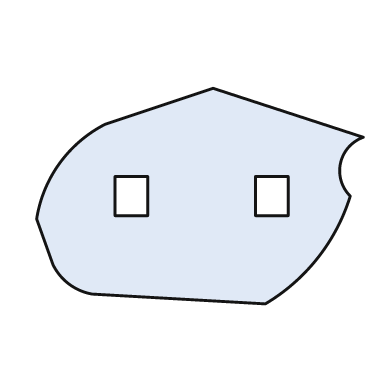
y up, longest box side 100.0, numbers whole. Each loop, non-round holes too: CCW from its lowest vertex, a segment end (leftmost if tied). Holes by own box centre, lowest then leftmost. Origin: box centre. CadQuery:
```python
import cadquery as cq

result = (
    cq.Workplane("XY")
    .moveTo(20.0, -33.0)
    .threePointArc((36.0, -19.0), (46.0, 0.0))
    .threePointArc((43.0, 10.0), (50.0, 18.0))
    .lineTo(4.0, 33.0)
    .lineTo(-29.0, 22.0)
    .threePointArc((-43.0, 10.0), (-50.0, -7.0))
    .lineTo(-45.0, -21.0)
    .threePointArc((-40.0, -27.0), (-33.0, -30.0))
    .close()
    .moveTo(-26.0, -6.0)
    .lineTo(-16.0, -6.0)
    .lineTo(-16.0, 6.0)
    .lineTo(-26.0, 6.0)
    .close()
    .moveTo(17.0, -6.0)
    .lineTo(27.0, -6.0)
    .lineTo(27.0, 6.0)
    .lineTo(17.0, 6.0)
    .close()
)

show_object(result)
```